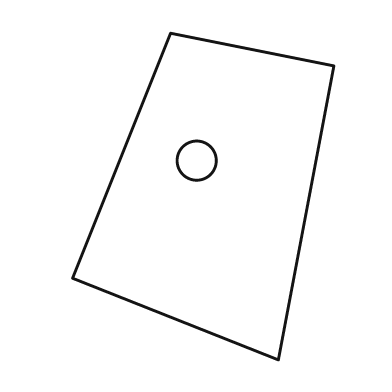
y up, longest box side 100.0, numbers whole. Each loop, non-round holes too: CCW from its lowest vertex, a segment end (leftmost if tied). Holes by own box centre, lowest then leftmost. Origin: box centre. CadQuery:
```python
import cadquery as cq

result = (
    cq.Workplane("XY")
    .moveTo(23.0, -50.0)
    .lineTo(40.0, 40.0)
    .lineTo(-10.0, 50.0)
    .lineTo(-40.0, -25.0)
    .close()
    .moveTo(-2.0, 11.0)
    .circle(6.0)
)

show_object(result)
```